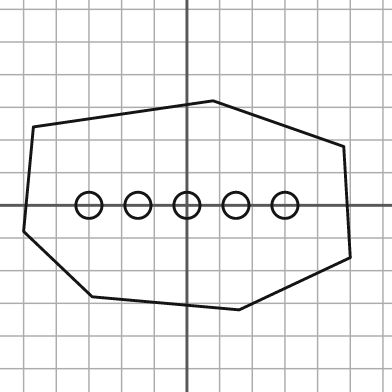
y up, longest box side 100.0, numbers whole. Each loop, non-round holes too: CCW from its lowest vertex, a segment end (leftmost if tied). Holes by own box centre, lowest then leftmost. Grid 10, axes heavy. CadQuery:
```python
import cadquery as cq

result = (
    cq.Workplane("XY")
    .moveTo(16.0, -32.0)
    .lineTo(50.0, -16.0)
    .lineTo(48.0, 18.0)
    .lineTo(8.0, 32.0)
    .lineTo(-47.0, 24.0)
    .lineTo(-50.0, -8.0)
    .lineTo(-29.0, -28.0)
    .close()
    .moveTo(-30.0, 0.0)
    .circle(4.0)
    .moveTo(-15.0, 0.0)
    .circle(4.0)
    .moveTo(0.0, 0.0)
    .circle(4.0)
    .moveTo(15.0, 0.0)
    .circle(4.0)
    .moveTo(30.0, 0.0)
    .circle(4.0)
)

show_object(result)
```